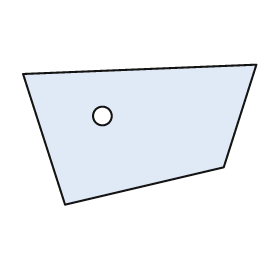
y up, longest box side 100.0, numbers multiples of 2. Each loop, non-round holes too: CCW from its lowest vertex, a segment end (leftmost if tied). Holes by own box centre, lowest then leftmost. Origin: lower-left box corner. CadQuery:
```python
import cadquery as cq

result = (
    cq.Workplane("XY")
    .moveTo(18.0, 0.0)
    .lineTo(86.0, 16.0)
    .lineTo(100.0, 60.0)
    .lineTo(0.0, 56.0)
    .close()
    .moveTo(34.0, 38.0)
    .circle(4.0)
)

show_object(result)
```